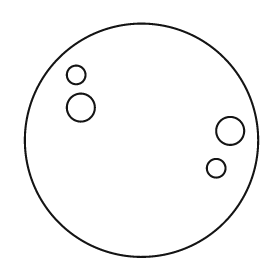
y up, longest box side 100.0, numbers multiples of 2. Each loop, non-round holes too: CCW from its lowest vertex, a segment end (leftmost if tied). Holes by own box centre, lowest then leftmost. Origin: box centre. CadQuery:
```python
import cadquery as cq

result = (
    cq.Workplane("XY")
    .moveTo(0.0, 0.0)
    .circle(50.0)
    .moveTo(32.0, -12.0)
    .circle(4.0)
    .moveTo(38.0, 4.0)
    .circle(6.0)
    .moveTo(-26.0, 14.0)
    .circle(6.0)
    .moveTo(-28.0, 28.0)
    .circle(4.0)
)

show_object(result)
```